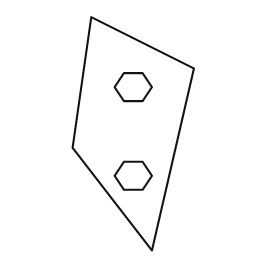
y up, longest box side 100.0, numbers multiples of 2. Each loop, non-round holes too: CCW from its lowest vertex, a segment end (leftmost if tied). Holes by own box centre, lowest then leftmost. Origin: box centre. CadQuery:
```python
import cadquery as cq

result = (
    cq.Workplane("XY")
    .moveTo(8.0, -50.0)
    .lineTo(26.0, 28.0)
    .lineTo(-18.0, 50.0)
    .lineTo(-26.0, -6.0)
    .close()
    .moveTo(-4.0, -24.0)
    .lineTo(4.0, -24.0)
    .lineTo(8.0, -18.0)
    .lineTo(4.0, -12.0)
    .lineTo(-4.0, -12.0)
    .lineTo(-8.0, -18.0)
    .close()
    .moveTo(-4.0, 14.0)
    .lineTo(4.0, 14.0)
    .lineTo(8.0, 20.0)
    .lineTo(4.0, 26.0)
    .lineTo(-4.0, 26.0)
    .lineTo(-8.0, 20.0)
    .close()
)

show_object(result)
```